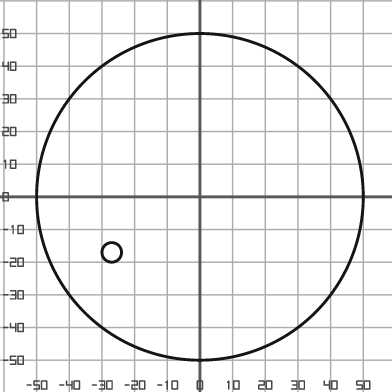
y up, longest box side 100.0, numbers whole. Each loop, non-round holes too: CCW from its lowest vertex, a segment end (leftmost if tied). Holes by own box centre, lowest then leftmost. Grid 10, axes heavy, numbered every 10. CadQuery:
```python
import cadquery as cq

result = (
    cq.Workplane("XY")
    .moveTo(0.0, 0.0)
    .circle(50.0)
    .moveTo(-27.0, -17.0)
    .circle(3.0)
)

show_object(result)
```